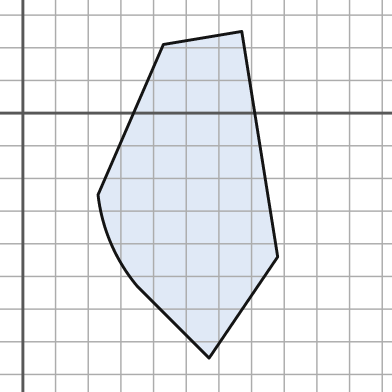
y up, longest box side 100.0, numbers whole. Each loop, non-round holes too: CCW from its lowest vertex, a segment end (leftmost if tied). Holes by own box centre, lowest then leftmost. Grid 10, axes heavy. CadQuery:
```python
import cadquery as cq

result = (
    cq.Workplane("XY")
    .moveTo(57.0, -75.0)
    .lineTo(78.0, -44.0)
    .lineTo(67.0, 25.0)
    .lineTo(43.0, 21.0)
    .lineTo(23.0, -25.0)
    .threePointArc((27.0, -40.0), (35.0, -53.0))
    .close()
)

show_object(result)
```